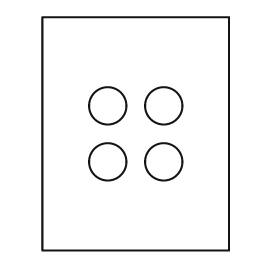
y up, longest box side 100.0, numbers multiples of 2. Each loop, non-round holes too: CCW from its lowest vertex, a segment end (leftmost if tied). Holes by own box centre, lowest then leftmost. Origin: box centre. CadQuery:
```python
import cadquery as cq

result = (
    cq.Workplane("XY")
    .moveTo(-40.0, -50.0)
    .lineTo(40.0, -50.0)
    .lineTo(40.0, 50.0)
    .lineTo(-40.0, 50.0)
    .close()
    .moveTo(-12.0, -12.0)
    .circle(8.0)
    .moveTo(12.0, -12.0)
    .circle(8.0)
    .moveTo(-12.0, 12.0)
    .circle(8.0)
    .moveTo(12.0, 12.0)
    .circle(8.0)
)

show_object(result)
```